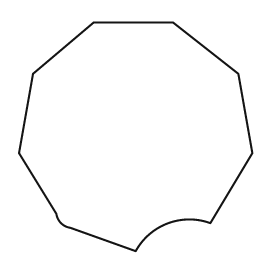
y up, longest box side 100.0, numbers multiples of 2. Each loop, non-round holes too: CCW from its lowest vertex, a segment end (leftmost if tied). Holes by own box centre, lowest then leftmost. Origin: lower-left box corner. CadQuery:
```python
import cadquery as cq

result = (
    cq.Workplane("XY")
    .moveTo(50.0, 0.0)
    .threePointArc((64.0, 12.0), (82.0, 12.0))
    .lineTo(100.0, 42.0)
    .lineTo(94.0, 76.0)
    .lineTo(66.0, 98.0)
    .lineTo(32.0, 98.0)
    .lineTo(6.0, 76.0)
    .lineTo(0.0, 42.0)
    .lineTo(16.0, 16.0)
    .threePointArc((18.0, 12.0), (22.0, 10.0))
    .close()
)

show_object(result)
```